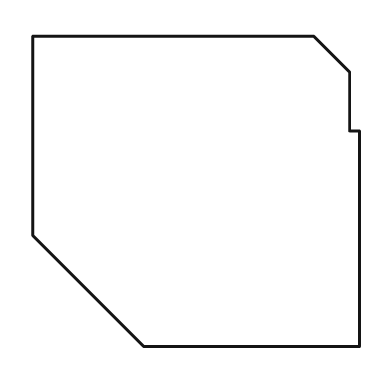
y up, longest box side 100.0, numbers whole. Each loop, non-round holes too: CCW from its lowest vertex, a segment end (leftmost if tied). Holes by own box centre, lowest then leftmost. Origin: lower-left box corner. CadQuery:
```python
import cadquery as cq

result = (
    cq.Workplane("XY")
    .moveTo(34.0, 0.0)
    .lineTo(100.0, 0.0)
    .lineTo(100.0, 66.0)
    .lineTo(97.0, 66.0)
    .lineTo(97.0, 84.0)
    .lineTo(86.0, 95.0)
    .lineTo(0.0, 95.0)
    .lineTo(0.0, 34.0)
    .close()
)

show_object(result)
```